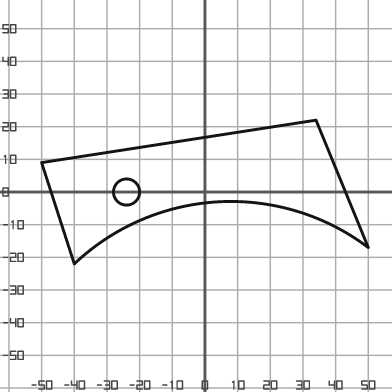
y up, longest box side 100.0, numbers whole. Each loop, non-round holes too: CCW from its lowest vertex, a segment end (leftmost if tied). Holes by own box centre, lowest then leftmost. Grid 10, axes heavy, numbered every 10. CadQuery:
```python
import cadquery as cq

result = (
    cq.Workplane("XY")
    .moveTo(-40.0, -22.0)
    .threePointArc((4.0, -3.0), (50.0, -17.0))
    .lineTo(34.0, 22.0)
    .lineTo(-50.0, 9.0)
    .close()
    .moveTo(-24.0, 0.0)
    .circle(4.0)
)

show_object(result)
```